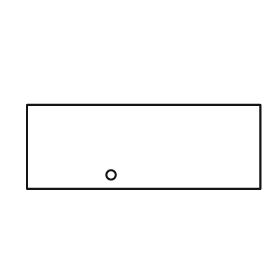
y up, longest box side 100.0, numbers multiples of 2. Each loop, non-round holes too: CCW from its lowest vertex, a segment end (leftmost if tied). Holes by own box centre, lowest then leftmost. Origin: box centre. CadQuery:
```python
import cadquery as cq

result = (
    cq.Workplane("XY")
    .moveTo(-50.0, -18.0)
    .lineTo(50.0, -18.0)
    .lineTo(50.0, 18.0)
    .lineTo(-50.0, 18.0)
    .close()
    .moveTo(-14.0, -12.0)
    .circle(2.0)
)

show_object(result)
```